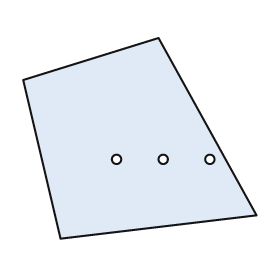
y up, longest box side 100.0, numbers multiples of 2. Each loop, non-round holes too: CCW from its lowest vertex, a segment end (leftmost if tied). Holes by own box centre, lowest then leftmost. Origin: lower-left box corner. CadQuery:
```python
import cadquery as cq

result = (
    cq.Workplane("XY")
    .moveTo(16.0, 0.0)
    .lineTo(100.0, 10.0)
    .lineTo(58.0, 86.0)
    .lineTo(0.0, 68.0)
    .close()
    .moveTo(40.0, 34.0)
    .circle(2.0)
    .moveTo(60.0, 34.0)
    .circle(2.0)
    .moveTo(80.0, 34.0)
    .circle(2.0)
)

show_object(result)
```